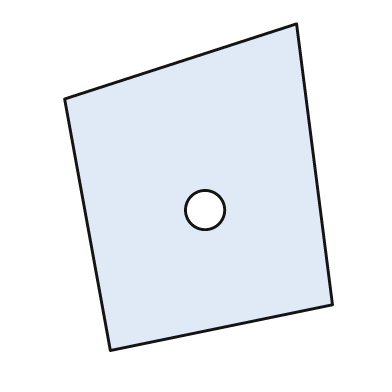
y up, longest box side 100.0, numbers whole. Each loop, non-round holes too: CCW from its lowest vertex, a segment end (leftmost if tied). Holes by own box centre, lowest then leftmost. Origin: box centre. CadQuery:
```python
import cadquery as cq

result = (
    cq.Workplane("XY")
    .moveTo(-27.0, -50.0)
    .lineTo(41.0, -36.0)
    .lineTo(30.0, 50.0)
    .lineTo(-41.0, 27.0)
    .close()
    .moveTo(2.0, -7.0)
    .circle(6.0)
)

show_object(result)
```